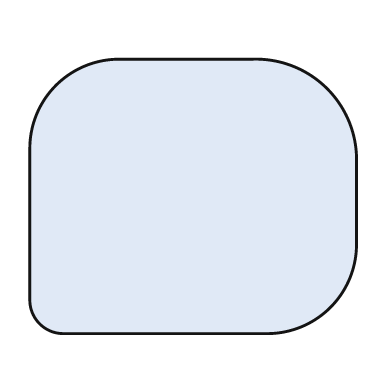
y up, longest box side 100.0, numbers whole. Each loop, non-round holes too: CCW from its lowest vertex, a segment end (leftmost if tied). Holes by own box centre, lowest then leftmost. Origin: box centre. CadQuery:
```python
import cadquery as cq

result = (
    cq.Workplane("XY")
    .moveTo(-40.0, -42.0)
    .lineTo(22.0, -42.0)
    .threePointArc((42.0, -34.0), (50.0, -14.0))
    .lineTo(50.0, 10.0)
    .threePointArc((41.0, 33.0), (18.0, 42.0))
    .lineTo(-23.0, 42.0)
    .threePointArc((-42.0, 34.0), (-50.0, 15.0))
    .lineTo(-50.0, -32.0)
    .threePointArc((-47.0, -39.0), (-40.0, -42.0))
    .close()
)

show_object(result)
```